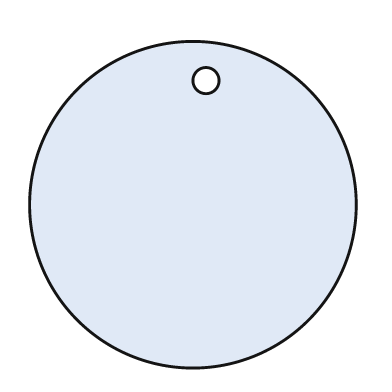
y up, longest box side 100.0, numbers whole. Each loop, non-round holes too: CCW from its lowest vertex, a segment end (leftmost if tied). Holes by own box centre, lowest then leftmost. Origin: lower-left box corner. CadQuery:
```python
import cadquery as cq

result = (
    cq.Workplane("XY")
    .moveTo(50.0, 50.0)
    .circle(50.0)
    .moveTo(54.0, 88.0)
    .circle(4.0)
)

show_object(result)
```